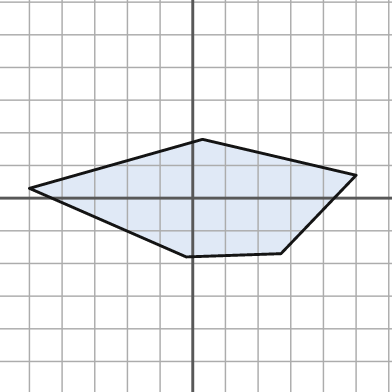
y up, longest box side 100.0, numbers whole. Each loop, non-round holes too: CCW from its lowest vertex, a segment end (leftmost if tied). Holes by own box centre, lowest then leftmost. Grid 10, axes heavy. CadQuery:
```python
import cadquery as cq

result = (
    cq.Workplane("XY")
    .moveTo(-2.0, -18.0)
    .lineTo(27.0, -17.0)
    .lineTo(50.0, 7.0)
    .lineTo(3.0, 18.0)
    .lineTo(-50.0, 3.0)
    .close()
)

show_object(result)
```